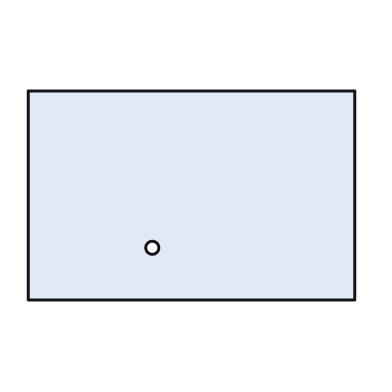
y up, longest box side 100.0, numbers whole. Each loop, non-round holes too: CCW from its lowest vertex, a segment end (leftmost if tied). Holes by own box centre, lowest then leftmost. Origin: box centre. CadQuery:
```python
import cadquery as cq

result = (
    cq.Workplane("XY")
    .moveTo(-50.0, -32.0)
    .lineTo(50.0, -32.0)
    .lineTo(50.0, 32.0)
    .lineTo(-50.0, 32.0)
    .close()
    .moveTo(-12.0, -16.0)
    .circle(2.0)
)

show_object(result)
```